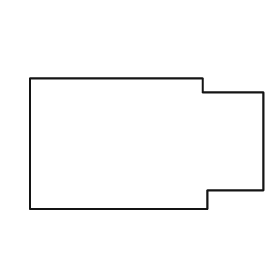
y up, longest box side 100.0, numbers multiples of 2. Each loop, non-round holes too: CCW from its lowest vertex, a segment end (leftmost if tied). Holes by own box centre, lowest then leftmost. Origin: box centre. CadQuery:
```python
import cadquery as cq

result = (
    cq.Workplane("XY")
    .moveTo(-50.0, -28.0)
    .lineTo(26.0, -28.0)
    .lineTo(26.0, -20.0)
    .lineTo(50.0, -20.0)
    .lineTo(50.0, 22.0)
    .lineTo(24.0, 22.0)
    .lineTo(24.0, 28.0)
    .lineTo(-50.0, 28.0)
    .close()
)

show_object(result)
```